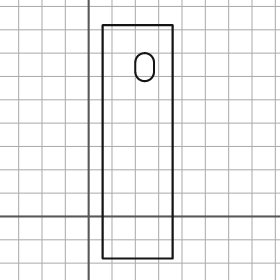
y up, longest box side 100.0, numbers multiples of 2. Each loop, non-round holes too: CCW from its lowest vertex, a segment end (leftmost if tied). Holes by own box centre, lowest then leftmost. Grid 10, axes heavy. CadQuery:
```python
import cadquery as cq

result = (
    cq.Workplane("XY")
    .moveTo(6.0, -18.0)
    .lineTo(36.0, -18.0)
    .lineTo(36.0, 82.0)
    .lineTo(6.0, 82.0)
    .close()
    .moveTo(20.0, 62.0)
    .threePointArc((24.0, 58.0), (28.0, 62.0))
    .lineTo(28.0, 66.0)
    .threePointArc((24.0, 70.0), (20.0, 66.0))
    .close()
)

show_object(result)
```